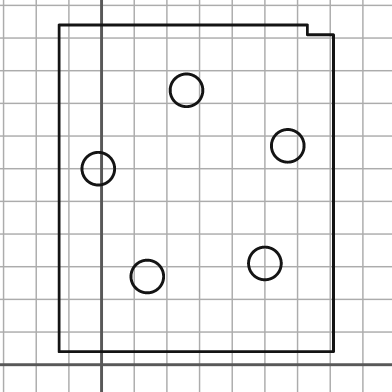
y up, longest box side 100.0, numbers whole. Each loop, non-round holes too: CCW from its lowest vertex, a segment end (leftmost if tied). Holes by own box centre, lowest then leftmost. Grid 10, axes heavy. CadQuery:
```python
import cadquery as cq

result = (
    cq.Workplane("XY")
    .moveTo(-13.0, 4.0)
    .lineTo(71.0, 4.0)
    .lineTo(71.0, 101.0)
    .lineTo(63.0, 101.0)
    .lineTo(63.0, 104.0)
    .lineTo(-13.0, 104.0)
    .close()
    .moveTo(14.0, 27.0)
    .circle(5.0)
    .moveTo(50.0, 31.0)
    .circle(5.0)
    .moveTo(-1.0, 60.0)
    .circle(5.0)
    .moveTo(57.0, 67.0)
    .circle(5.0)
    .moveTo(26.0, 84.0)
    .circle(5.0)
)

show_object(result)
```